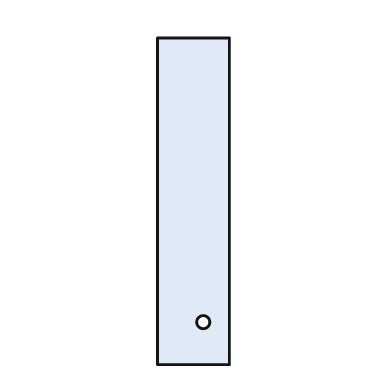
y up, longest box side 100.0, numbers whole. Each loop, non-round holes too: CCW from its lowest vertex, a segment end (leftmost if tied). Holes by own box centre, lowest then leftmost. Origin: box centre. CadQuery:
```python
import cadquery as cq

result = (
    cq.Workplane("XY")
    .moveTo(-11.0, -50.0)
    .lineTo(11.0, -50.0)
    .lineTo(11.0, 50.0)
    .lineTo(-11.0, 50.0)
    .close()
    .moveTo(3.0, -37.0)
    .circle(2.0)
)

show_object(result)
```